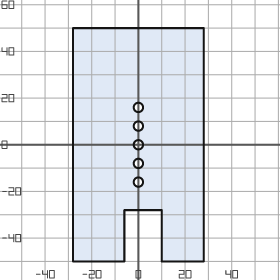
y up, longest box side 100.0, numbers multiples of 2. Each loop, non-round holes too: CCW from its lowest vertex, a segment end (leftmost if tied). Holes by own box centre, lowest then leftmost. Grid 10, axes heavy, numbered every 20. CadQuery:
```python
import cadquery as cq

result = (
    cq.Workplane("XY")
    .moveTo(-28.0, -50.0)
    .lineTo(-6.0, -50.0)
    .lineTo(-6.0, -28.0)
    .lineTo(10.0, -28.0)
    .lineTo(10.0, -50.0)
    .lineTo(28.0, -50.0)
    .lineTo(28.0, 50.0)
    .lineTo(-28.0, 50.0)
    .close()
    .moveTo(0.0, -16.0)
    .circle(2.0)
    .moveTo(0.0, -8.0)
    .circle(2.0)
    .moveTo(0.0, 0.0)
    .circle(2.0)
    .moveTo(0.0, 8.0)
    .circle(2.0)
    .moveTo(0.0, 16.0)
    .circle(2.0)
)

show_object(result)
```